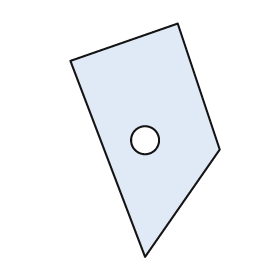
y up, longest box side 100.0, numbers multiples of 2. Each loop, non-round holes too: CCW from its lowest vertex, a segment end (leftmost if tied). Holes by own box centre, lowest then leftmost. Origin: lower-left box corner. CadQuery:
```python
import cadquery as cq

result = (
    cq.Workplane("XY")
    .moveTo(32.0, 0.0)
    .lineTo(64.0, 46.0)
    .lineTo(46.0, 100.0)
    .lineTo(0.0, 84.0)
    .close()
    .moveTo(32.0, 50.0)
    .circle(6.0)
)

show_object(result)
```